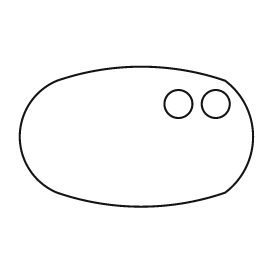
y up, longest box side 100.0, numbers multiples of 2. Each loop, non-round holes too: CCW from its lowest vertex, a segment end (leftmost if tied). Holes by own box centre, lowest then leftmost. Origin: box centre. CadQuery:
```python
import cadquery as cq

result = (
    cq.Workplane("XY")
    .moveTo(-34.0, -24.0)
    .threePointArc((2.0, -30.0), (38.0, -24.0))
    .threePointArc((50.0, 0.0), (38.0, 24.0))
    .threePointArc((2.0, 30.0), (-34.0, 24.0))
    .threePointArc((-50.0, 0.0), (-34.0, -24.0))
    .close()
    .moveTo(18.0, 14.0)
    .circle(6.0)
    .moveTo(34.0, 14.0)
    .circle(6.0)
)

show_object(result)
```